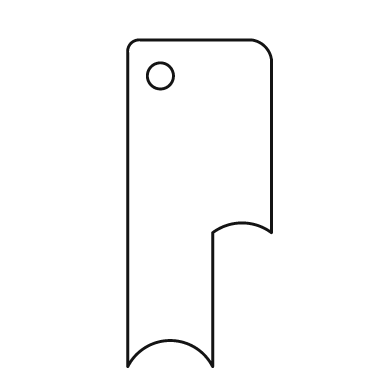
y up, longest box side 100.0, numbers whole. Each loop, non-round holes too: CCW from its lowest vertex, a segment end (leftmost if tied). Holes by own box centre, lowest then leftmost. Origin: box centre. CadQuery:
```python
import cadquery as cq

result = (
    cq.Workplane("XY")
    .moveTo(-22.0, -50.0)
    .threePointArc((-9.0, -42.0), (4.0, -50.0))
    .lineTo(4.0, -9.0)
    .threePointArc((13.0, -6.0), (22.0, -9.0))
    .lineTo(22.0, 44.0)
    .threePointArc((20.0, 48.0), (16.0, 50.0))
    .lineTo(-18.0, 50.0)
    .threePointArc((-21.0, 49.0), (-22.0, 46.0))
    .close()
    .moveTo(-12.0, 39.0)
    .circle(4.0)
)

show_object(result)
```